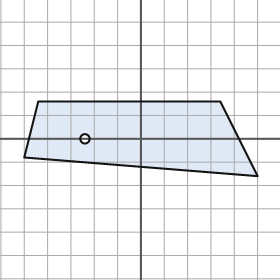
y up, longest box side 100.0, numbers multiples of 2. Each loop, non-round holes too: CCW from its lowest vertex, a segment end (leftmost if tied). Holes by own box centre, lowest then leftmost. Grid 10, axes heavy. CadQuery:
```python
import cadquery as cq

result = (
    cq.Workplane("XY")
    .moveTo(50.0, -16.0)
    .lineTo(34.0, 16.0)
    .lineTo(-44.0, 16.0)
    .lineTo(-50.0, -8.0)
    .close()
    .moveTo(-24.0, 0.0)
    .circle(2.0)
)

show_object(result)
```